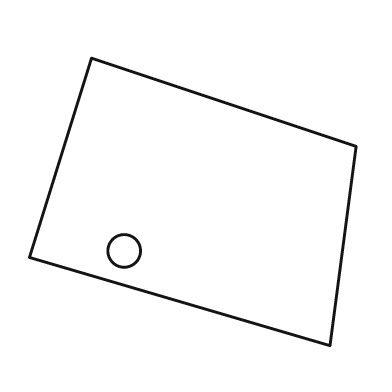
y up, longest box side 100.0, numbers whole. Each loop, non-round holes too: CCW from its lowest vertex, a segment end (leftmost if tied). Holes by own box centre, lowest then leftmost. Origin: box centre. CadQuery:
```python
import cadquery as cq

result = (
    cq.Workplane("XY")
    .moveTo(42.0, -44.0)
    .lineTo(50.0, 17.0)
    .lineTo(-31.0, 44.0)
    .lineTo(-50.0, -17.0)
    .close()
    .moveTo(-21.0, -15.0)
    .circle(5.0)
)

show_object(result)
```